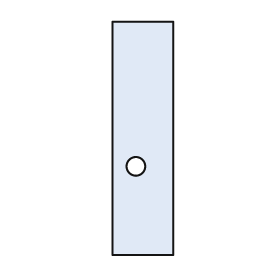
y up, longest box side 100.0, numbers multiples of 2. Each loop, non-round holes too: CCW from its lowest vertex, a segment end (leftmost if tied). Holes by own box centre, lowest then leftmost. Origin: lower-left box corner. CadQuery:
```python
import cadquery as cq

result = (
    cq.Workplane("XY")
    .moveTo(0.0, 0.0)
    .lineTo(26.0, 0.0)
    .lineTo(26.0, 100.0)
    .lineTo(0.0, 100.0)
    .close()
    .moveTo(10.0, 38.0)
    .circle(4.0)
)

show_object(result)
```